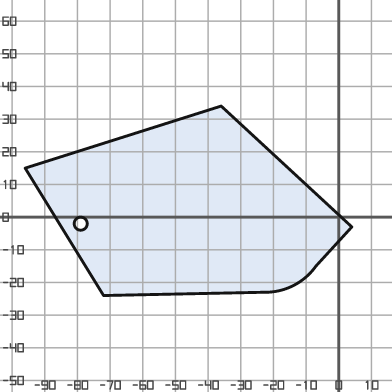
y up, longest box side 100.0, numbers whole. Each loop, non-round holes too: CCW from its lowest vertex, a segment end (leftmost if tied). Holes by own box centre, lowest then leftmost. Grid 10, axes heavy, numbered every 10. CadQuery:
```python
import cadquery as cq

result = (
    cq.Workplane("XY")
    .moveTo(-72.0, -24.0)
    .lineTo(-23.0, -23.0)
    .threePointArc((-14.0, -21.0), (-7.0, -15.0))
    .lineTo(4.0, -3.0)
    .lineTo(-36.0, 34.0)
    .lineTo(-96.0, 15.0)
    .close()
    .moveTo(-79.0, -2.0)
    .circle(2.0)
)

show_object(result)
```